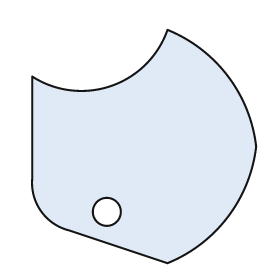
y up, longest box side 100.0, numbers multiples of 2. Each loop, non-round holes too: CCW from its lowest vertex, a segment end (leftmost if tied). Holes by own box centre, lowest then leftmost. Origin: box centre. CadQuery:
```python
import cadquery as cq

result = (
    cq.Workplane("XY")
    .moveTo(10.0, -50.0)
    .threePointArc((36.0, -30.0), (48.0, 0.0))
    .threePointArc((36.0, 30.0), (10.0, 50.0))
    .threePointArc((-14.0, 26.0), (-48.0, 30.0))
    .lineTo(-48.0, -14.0)
    .threePointArc((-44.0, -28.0), (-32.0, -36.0))
    .close()
    .moveTo(-16.0, -28.0)
    .circle(6.0)
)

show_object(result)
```